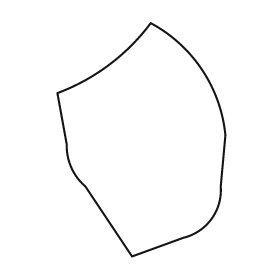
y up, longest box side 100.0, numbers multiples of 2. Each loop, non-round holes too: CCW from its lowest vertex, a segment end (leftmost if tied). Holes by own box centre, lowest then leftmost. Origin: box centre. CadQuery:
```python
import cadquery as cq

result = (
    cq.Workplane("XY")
    .moveTo(-4.0, -50.0)
    .lineTo(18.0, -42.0)
    .threePointArc((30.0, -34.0), (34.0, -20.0))
    .lineTo(36.0, 2.0)
    .threePointArc((26.0, 30.0), (4.0, 50.0))
    .threePointArc((-14.0, 32.0), (-36.0, 20.0))
    .lineTo(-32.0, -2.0)
    .threePointArc((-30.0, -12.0), (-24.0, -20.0))
    .close()
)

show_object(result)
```